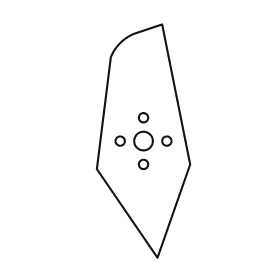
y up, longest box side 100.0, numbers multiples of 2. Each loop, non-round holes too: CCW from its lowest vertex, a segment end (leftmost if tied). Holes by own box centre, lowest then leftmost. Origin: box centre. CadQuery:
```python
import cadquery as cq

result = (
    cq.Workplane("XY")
    .moveTo(6.0, -50.0)
    .lineTo(20.0, -10.0)
    .lineTo(8.0, 50.0)
    .lineTo(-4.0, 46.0)
    .threePointArc((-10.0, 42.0), (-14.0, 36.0))
    .lineTo(-20.0, -12.0)
    .close()
    .moveTo(0.0, -10.0)
    .circle(2.0)
    .moveTo(-10.0, 0.0)
    .circle(2.0)
    .moveTo(0.0, 0.0)
    .circle(4.0)
    .moveTo(10.0, 0.0)
    .circle(2.0)
    .moveTo(0.0, 10.0)
    .circle(2.0)
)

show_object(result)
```